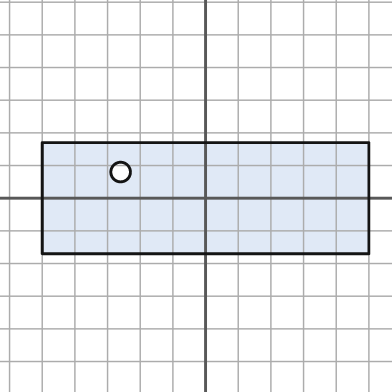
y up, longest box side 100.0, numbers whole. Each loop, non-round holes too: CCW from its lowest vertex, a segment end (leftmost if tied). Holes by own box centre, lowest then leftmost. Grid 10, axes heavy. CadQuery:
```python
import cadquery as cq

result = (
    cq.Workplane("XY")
    .moveTo(-50.0, -17.0)
    .lineTo(50.0, -17.0)
    .lineTo(50.0, 17.0)
    .lineTo(-50.0, 17.0)
    .close()
    .moveTo(-26.0, 8.0)
    .circle(3.0)
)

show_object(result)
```